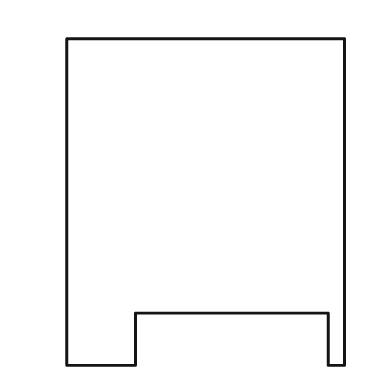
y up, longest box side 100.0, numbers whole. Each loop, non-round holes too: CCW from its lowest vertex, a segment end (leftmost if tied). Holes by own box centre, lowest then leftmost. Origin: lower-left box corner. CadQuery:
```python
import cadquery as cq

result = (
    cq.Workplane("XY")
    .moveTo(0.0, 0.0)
    .lineTo(21.0, 0.0)
    .lineTo(21.0, 16.0)
    .lineTo(80.0, 16.0)
    .lineTo(80.0, 0.0)
    .lineTo(85.0, 0.0)
    .lineTo(85.0, 100.0)
    .lineTo(0.0, 100.0)
    .close()
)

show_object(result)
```